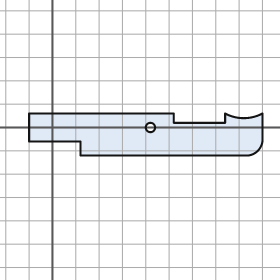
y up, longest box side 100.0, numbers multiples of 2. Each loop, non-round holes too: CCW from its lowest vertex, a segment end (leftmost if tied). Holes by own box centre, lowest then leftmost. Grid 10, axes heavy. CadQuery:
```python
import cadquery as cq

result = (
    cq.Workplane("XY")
    .moveTo(12.0, -12.0)
    .lineTo(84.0, -12.0)
    .threePointArc((88.0, -10.0), (90.0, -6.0))
    .lineTo(90.0, 6.0)
    .threePointArc((82.0, 4.0), (74.0, 6.0))
    .lineTo(74.0, 2.0)
    .lineTo(52.0, 2.0)
    .lineTo(52.0, 6.0)
    .lineTo(-10.0, 6.0)
    .lineTo(-10.0, -6.0)
    .lineTo(12.0, -6.0)
    .close()
    .moveTo(42.0, 0.0)
    .circle(2.0)
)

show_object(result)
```